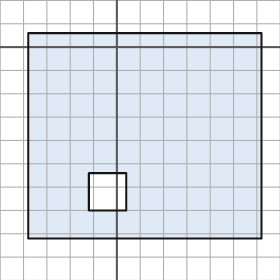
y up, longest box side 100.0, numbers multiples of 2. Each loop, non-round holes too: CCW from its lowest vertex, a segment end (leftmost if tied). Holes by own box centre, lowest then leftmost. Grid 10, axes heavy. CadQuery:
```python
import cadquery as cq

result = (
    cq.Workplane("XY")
    .moveTo(-38.0, -82.0)
    .lineTo(62.0, -82.0)
    .lineTo(62.0, 6.0)
    .lineTo(-38.0, 6.0)
    .close()
    .moveTo(-12.0, -70.0)
    .lineTo(4.0, -70.0)
    .lineTo(4.0, -54.0)
    .lineTo(-12.0, -54.0)
    .close()
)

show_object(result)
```